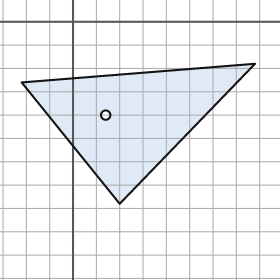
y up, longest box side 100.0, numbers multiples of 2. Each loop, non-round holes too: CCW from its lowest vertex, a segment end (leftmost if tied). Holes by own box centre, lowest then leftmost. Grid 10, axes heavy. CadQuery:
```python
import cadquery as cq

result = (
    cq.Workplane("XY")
    .moveTo(20.0, -78.0)
    .lineTo(78.0, -18.0)
    .lineTo(-22.0, -26.0)
    .close()
    .moveTo(14.0, -40.0)
    .circle(2.0)
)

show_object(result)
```